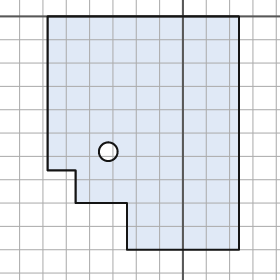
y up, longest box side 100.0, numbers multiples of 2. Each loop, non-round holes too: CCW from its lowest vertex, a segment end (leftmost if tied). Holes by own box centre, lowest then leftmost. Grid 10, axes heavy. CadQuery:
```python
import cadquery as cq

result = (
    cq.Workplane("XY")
    .moveTo(-24.0, -100.0)
    .lineTo(24.0, -100.0)
    .lineTo(24.0, 0.0)
    .lineTo(-58.0, 0.0)
    .lineTo(-58.0, -66.0)
    .lineTo(-46.0, -66.0)
    .lineTo(-46.0, -80.0)
    .lineTo(-24.0, -80.0)
    .close()
    .moveTo(-32.0, -58.0)
    .circle(4.0)
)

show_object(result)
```